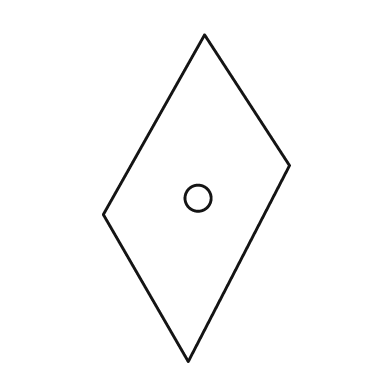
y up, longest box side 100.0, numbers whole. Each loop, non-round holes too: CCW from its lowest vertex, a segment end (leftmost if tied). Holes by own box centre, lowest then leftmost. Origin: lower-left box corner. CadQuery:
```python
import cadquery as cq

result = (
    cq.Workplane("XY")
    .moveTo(26.0, 0.0)
    .lineTo(57.0, 60.0)
    .lineTo(31.0, 100.0)
    .lineTo(0.0, 45.0)
    .close()
    .moveTo(29.0, 50.0)
    .circle(4.0)
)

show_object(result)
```